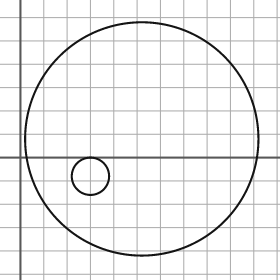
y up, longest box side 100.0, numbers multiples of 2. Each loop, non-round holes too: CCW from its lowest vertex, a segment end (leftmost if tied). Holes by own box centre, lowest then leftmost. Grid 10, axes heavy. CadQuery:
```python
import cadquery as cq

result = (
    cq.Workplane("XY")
    .moveTo(52.0, 8.0)
    .circle(50.0)
    .moveTo(30.0, -8.0)
    .circle(8.0)
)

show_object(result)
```